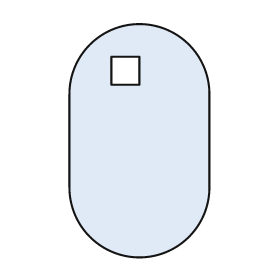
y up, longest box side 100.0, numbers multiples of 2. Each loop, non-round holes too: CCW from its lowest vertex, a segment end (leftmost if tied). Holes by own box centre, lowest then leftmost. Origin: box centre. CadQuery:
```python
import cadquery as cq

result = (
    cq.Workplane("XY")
    .moveTo(-30.0, -20.0)
    .threePointArc((0.0, -50.0), (30.0, -20.0))
    .lineTo(30.0, 20.0)
    .threePointArc((0.0, 50.0), (-30.0, 20.0))
    .close()
    .moveTo(-12.0, 24.0)
    .lineTo(0.0, 24.0)
    .lineTo(0.0, 36.0)
    .lineTo(-12.0, 36.0)
    .close()
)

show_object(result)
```